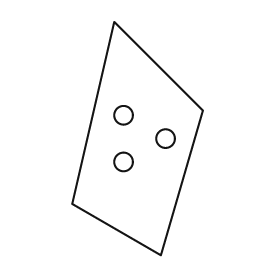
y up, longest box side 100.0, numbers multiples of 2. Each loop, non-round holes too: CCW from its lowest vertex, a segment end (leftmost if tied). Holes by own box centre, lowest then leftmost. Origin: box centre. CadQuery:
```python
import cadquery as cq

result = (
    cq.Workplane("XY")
    .moveTo(10.0, -50.0)
    .lineTo(28.0, 12.0)
    .lineTo(-10.0, 50.0)
    .lineTo(-28.0, -28.0)
    .close()
    .moveTo(-6.0, -10.0)
    .circle(4.0)
    .moveTo(12.0, 0.0)
    .circle(4.0)
    .moveTo(-6.0, 10.0)
    .circle(4.0)
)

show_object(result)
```